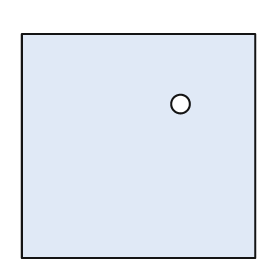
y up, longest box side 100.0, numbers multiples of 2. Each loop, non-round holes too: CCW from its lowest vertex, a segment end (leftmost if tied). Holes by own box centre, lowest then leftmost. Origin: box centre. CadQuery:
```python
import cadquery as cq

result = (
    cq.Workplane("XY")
    .moveTo(-50.0, -48.0)
    .lineTo(50.0, -48.0)
    .lineTo(50.0, 48.0)
    .lineTo(-50.0, 48.0)
    .close()
    .moveTo(18.0, 18.0)
    .circle(4.0)
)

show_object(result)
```